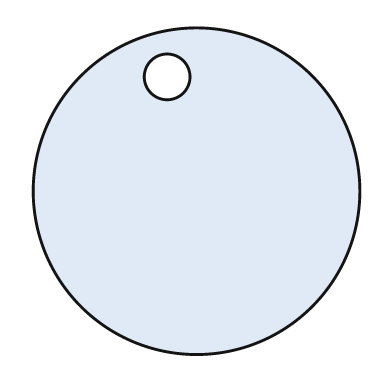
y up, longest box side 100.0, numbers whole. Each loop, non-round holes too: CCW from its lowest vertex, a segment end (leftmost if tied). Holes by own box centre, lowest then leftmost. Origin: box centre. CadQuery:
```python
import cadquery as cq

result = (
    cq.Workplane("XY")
    .moveTo(0.0, 0.0)
    .circle(50.0)
    .moveTo(-9.0, 35.0)
    .circle(7.0)
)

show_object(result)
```